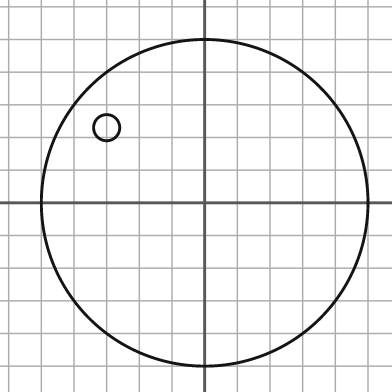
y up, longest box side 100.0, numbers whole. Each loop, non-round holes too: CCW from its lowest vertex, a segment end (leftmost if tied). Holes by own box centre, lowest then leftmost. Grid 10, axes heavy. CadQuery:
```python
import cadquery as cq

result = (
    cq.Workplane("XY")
    .moveTo(0.0, 0.0)
    .circle(50.0)
    .moveTo(-30.0, 23.0)
    .circle(4.0)
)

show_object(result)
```